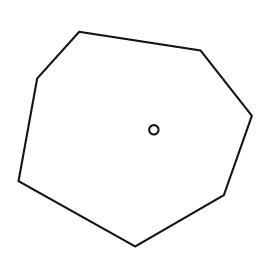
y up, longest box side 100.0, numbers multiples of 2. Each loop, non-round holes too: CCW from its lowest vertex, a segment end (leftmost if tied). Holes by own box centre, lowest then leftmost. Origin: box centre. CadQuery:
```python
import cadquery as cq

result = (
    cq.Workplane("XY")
    .moveTo(0.0, -46.0)
    .lineTo(38.0, -24.0)
    .lineTo(50.0, 10.0)
    .lineTo(28.0, 38.0)
    .lineTo(-24.0, 46.0)
    .lineTo(-42.0, 26.0)
    .lineTo(-50.0, -18.0)
    .close()
    .moveTo(8.0, 4.0)
    .circle(2.0)
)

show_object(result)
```